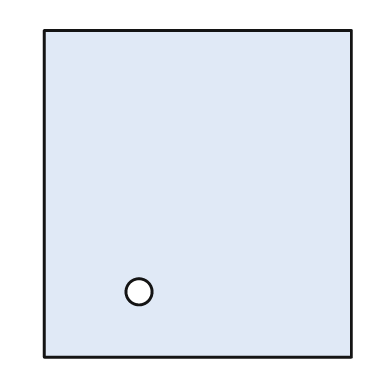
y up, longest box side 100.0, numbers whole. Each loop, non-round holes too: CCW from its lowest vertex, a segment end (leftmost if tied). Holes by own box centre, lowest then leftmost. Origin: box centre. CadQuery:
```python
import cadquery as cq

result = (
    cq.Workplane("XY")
    .moveTo(-47.0, -50.0)
    .lineTo(47.0, -50.0)
    .lineTo(47.0, 50.0)
    .lineTo(-47.0, 50.0)
    .close()
    .moveTo(-18.0, -30.0)
    .circle(4.0)
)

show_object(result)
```